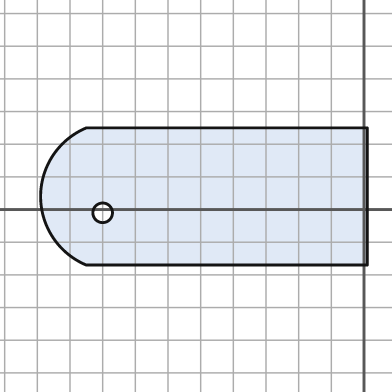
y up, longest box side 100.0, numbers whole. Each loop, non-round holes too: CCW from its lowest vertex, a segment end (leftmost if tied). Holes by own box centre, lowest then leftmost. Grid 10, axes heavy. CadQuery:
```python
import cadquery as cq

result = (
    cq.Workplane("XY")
    .moveTo(-85.0, -17.0)
    .lineTo(1.0, -17.0)
    .lineTo(1.0, 25.0)
    .lineTo(-85.0, 25.0)
    .threePointArc((-99.0, 4.0), (-85.0, -17.0))
    .close()
    .moveTo(-80.0, -1.0)
    .circle(3.0)
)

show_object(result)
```